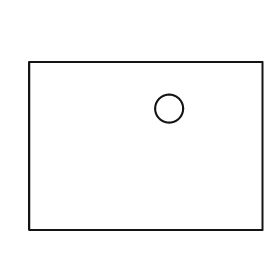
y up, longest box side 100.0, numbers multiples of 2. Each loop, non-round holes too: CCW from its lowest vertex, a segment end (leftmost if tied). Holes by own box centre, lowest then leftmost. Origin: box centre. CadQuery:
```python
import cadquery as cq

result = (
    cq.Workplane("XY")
    .moveTo(-50.0, -36.0)
    .lineTo(50.0, -36.0)
    .lineTo(50.0, 36.0)
    .lineTo(-50.0, 36.0)
    .close()
    .moveTo(10.0, 16.0)
    .circle(6.0)
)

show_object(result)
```